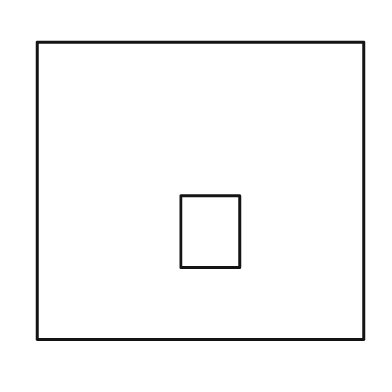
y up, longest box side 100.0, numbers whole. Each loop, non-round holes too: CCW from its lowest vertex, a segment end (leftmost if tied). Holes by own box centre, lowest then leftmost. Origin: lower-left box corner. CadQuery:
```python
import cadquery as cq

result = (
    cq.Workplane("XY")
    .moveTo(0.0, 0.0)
    .lineTo(100.0, 0.0)
    .lineTo(100.0, 91.0)
    .lineTo(0.0, 91.0)
    .close()
    .moveTo(44.0, 22.0)
    .lineTo(62.0, 22.0)
    .lineTo(62.0, 44.0)
    .lineTo(44.0, 44.0)
    .close()
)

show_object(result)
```